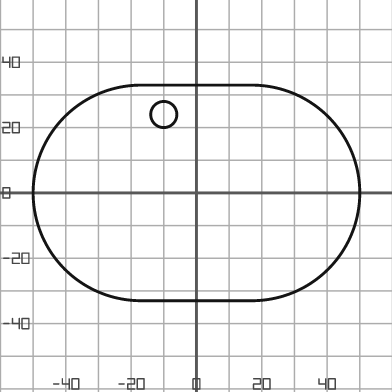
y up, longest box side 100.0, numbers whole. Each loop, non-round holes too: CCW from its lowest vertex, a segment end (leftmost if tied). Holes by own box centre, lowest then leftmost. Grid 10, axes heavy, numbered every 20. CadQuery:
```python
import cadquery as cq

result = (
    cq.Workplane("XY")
    .moveTo(-17.0, -33.0)
    .lineTo(17.0, -33.0)
    .threePointArc((50.0, 0.0), (17.0, 33.0))
    .lineTo(-17.0, 33.0)
    .threePointArc((-50.0, 0.0), (-17.0, -33.0))
    .close()
    .moveTo(-10.0, 24.0)
    .circle(4.0)
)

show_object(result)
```